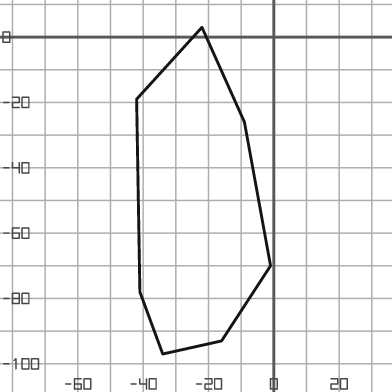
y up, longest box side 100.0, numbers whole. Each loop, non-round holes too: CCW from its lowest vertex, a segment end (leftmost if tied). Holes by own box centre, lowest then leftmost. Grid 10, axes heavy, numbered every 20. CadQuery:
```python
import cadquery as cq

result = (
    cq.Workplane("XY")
    .moveTo(-34.0, -97.0)
    .lineTo(-16.0, -93.0)
    .lineTo(-1.0, -70.0)
    .lineTo(-9.0, -26.0)
    .lineTo(-22.0, 3.0)
    .lineTo(-42.0, -19.0)
    .lineTo(-41.0, -78.0)
    .close()
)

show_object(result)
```